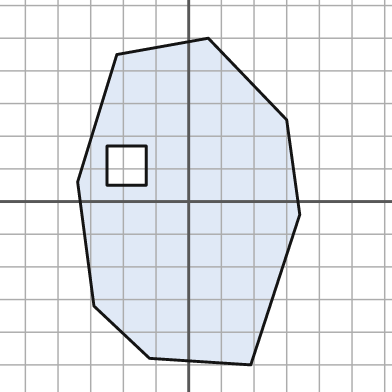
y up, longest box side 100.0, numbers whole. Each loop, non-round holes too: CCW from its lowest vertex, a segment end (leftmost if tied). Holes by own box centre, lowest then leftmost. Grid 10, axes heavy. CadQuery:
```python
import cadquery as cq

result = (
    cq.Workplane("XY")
    .moveTo(19.0, -50.0)
    .lineTo(34.0, -4.0)
    .lineTo(30.0, 25.0)
    .lineTo(6.0, 50.0)
    .lineTo(-22.0, 45.0)
    .lineTo(-34.0, 6.0)
    .lineTo(-29.0, -32.0)
    .lineTo(-12.0, -48.0)
    .close()
    .moveTo(-25.0, 5.0)
    .lineTo(-13.0, 5.0)
    .lineTo(-13.0, 17.0)
    .lineTo(-25.0, 17.0)
    .close()
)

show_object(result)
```